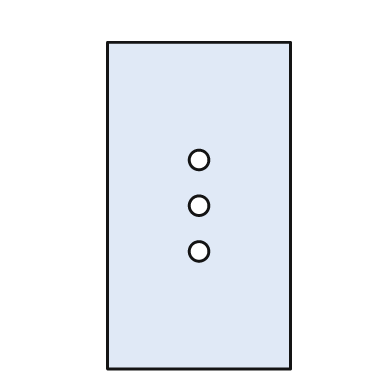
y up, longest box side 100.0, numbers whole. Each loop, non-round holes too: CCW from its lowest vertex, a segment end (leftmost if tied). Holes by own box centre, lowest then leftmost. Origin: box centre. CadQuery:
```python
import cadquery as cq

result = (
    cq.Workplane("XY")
    .moveTo(-28.0, -50.0)
    .lineTo(28.0, -50.0)
    .lineTo(28.0, 50.0)
    .lineTo(-28.0, 50.0)
    .close()
    .moveTo(0.0, -14.0)
    .circle(3.0)
    .moveTo(0.0, 0.0)
    .circle(3.0)
    .moveTo(0.0, 14.0)
    .circle(3.0)
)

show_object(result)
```